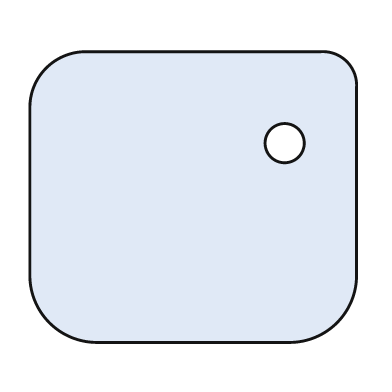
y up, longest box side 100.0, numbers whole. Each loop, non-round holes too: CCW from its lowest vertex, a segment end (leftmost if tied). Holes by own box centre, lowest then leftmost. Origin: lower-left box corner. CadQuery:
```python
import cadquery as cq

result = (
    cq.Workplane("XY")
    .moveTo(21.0, 0.0)
    .lineTo(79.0, 0.0)
    .threePointArc((94.0, 6.0), (100.0, 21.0))
    .lineTo(100.0, 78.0)
    .threePointArc((97.0, 86.0), (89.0, 89.0))
    .lineTo(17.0, 89.0)
    .threePointArc((5.0, 84.0), (0.0, 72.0))
    .lineTo(0.0, 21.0)
    .threePointArc((6.0, 6.0), (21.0, 0.0))
    .close()
    .moveTo(78.0, 61.0)
    .circle(6.0)
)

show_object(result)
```